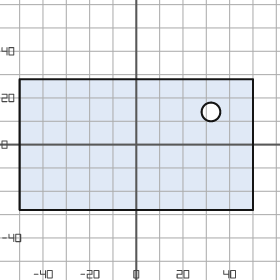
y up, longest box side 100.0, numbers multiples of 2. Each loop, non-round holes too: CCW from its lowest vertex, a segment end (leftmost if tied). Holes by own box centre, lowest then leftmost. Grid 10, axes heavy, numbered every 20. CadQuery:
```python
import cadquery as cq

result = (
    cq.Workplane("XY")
    .moveTo(-50.0, -28.0)
    .lineTo(50.0, -28.0)
    .lineTo(50.0, 28.0)
    .lineTo(-50.0, 28.0)
    .close()
    .moveTo(32.0, 14.0)
    .circle(4.0)
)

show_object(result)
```